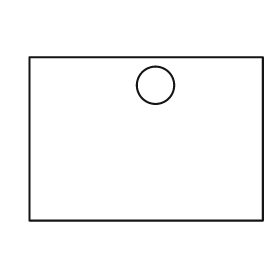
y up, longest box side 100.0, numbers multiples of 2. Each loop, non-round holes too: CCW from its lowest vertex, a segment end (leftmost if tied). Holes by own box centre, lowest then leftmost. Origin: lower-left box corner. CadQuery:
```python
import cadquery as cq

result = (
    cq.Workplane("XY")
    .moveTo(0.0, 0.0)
    .lineTo(100.0, 0.0)
    .lineTo(100.0, 70.0)
    .lineTo(0.0, 70.0)
    .close()
    .moveTo(54.0, 58.0)
    .circle(8.0)
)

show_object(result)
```